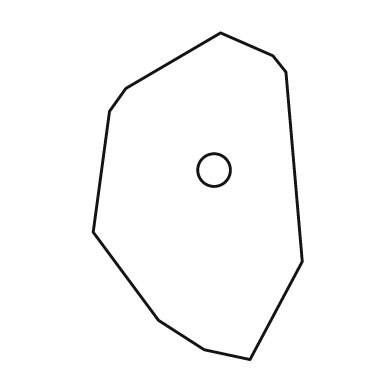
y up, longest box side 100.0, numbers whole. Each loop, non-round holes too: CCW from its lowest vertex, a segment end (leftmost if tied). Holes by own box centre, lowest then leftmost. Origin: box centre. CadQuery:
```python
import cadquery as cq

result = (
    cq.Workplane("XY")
    .moveTo(16.0, -50.0)
    .lineTo(32.0, -20.0)
    .lineTo(27.0, 38.0)
    .lineTo(23.0, 43.0)
    .lineTo(7.0, 50.0)
    .lineTo(-22.0, 33.0)
    .lineTo(-27.0, 26.0)
    .lineTo(-32.0, -11.0)
    .lineTo(-12.0, -38.0)
    .lineTo(2.0, -47.0)
    .close()
    .moveTo(5.0, 8.0)
    .circle(5.0)
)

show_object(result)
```